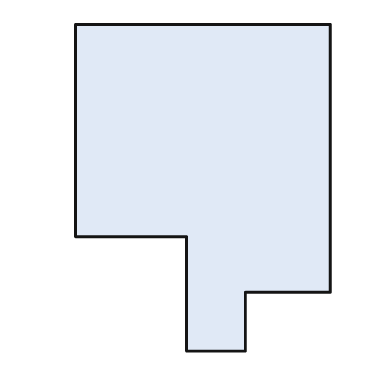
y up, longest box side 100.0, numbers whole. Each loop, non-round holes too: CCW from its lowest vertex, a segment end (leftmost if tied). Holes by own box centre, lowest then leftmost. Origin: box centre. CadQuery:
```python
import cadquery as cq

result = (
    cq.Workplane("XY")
    .moveTo(-5.0, -50.0)
    .lineTo(13.0, -50.0)
    .lineTo(13.0, -32.0)
    .lineTo(39.0, -32.0)
    .lineTo(39.0, 50.0)
    .lineTo(-39.0, 50.0)
    .lineTo(-39.0, -15.0)
    .lineTo(-5.0, -15.0)
    .close()
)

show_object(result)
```